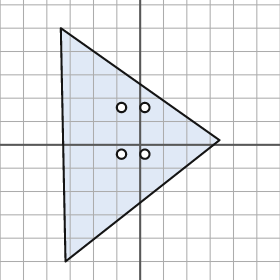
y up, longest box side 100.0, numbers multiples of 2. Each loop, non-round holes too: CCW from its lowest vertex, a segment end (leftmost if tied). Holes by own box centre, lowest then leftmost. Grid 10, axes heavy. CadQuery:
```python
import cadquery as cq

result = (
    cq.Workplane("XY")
    .moveTo(-32.0, -50.0)
    .lineTo(34.0, 2.0)
    .lineTo(-34.0, 50.0)
    .close()
    .moveTo(-8.0, -4.0)
    .circle(2.0)
    .moveTo(2.0, -4.0)
    .circle(2.0)
    .moveTo(-8.0, 16.0)
    .circle(2.0)
    .moveTo(2.0, 16.0)
    .circle(2.0)
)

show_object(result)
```